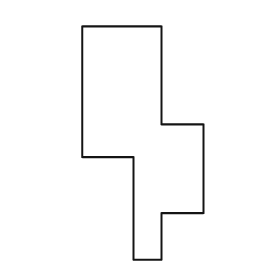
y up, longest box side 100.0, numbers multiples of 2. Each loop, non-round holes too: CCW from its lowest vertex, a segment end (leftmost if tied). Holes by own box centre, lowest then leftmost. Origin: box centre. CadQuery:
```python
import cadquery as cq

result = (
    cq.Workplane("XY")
    .moveTo(-4.0, -50.0)
    .lineTo(8.0, -50.0)
    .lineTo(8.0, -30.0)
    .lineTo(26.0, -30.0)
    .lineTo(26.0, 8.0)
    .lineTo(8.0, 8.0)
    .lineTo(8.0, 50.0)
    .lineTo(-26.0, 50.0)
    .lineTo(-26.0, -6.0)
    .lineTo(-4.0, -6.0)
    .close()
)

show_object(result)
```